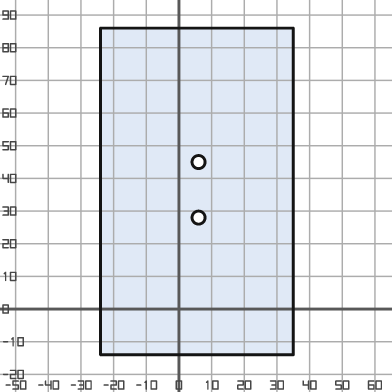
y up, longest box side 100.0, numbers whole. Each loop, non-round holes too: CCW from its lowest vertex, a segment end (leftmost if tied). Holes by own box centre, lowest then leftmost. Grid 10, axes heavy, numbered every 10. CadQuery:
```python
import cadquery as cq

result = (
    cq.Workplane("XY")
    .moveTo(-24.0, -14.0)
    .lineTo(35.0, -14.0)
    .lineTo(35.0, 86.0)
    .lineTo(-24.0, 86.0)
    .close()
    .moveTo(6.0, 28.0)
    .circle(2.0)
    .moveTo(6.0, 45.0)
    .circle(2.0)
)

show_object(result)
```